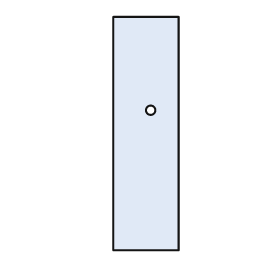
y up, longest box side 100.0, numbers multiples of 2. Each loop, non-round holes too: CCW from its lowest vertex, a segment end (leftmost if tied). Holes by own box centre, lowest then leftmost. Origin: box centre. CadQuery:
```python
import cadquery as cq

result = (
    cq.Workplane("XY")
    .moveTo(-14.0, -50.0)
    .lineTo(14.0, -50.0)
    .lineTo(14.0, 50.0)
    .lineTo(-14.0, 50.0)
    .close()
    .moveTo(2.0, 10.0)
    .circle(2.0)
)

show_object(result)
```